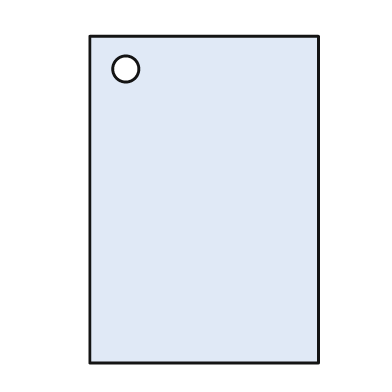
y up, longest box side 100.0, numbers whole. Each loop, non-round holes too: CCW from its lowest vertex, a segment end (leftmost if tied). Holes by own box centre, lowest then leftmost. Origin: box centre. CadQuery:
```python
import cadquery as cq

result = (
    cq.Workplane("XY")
    .moveTo(-35.0, -50.0)
    .lineTo(35.0, -50.0)
    .lineTo(35.0, 50.0)
    .lineTo(-35.0, 50.0)
    .close()
    .moveTo(-24.0, 40.0)
    .circle(4.0)
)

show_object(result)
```